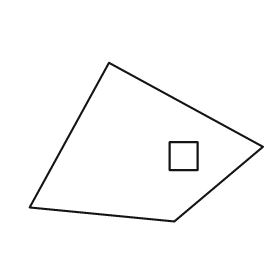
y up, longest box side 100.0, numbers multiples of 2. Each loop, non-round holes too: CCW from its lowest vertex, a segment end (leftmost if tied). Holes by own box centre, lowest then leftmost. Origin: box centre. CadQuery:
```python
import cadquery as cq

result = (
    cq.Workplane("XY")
    .moveTo(12.0, -34.0)
    .lineTo(50.0, -2.0)
    .lineTo(-16.0, 34.0)
    .lineTo(-50.0, -28.0)
    .close()
    .moveTo(10.0, -12.0)
    .lineTo(22.0, -12.0)
    .lineTo(22.0, 0.0)
    .lineTo(10.0, 0.0)
    .close()
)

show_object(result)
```